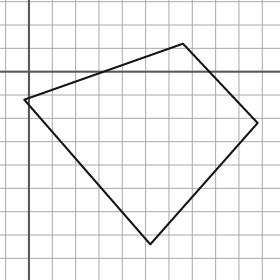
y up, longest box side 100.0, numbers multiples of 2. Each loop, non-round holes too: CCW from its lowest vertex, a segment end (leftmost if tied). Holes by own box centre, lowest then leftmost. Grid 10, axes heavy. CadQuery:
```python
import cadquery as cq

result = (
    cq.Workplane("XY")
    .moveTo(52.0, -74.0)
    .lineTo(98.0, -22.0)
    .lineTo(66.0, 12.0)
    .lineTo(-2.0, -12.0)
    .close()
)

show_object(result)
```